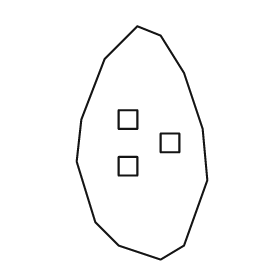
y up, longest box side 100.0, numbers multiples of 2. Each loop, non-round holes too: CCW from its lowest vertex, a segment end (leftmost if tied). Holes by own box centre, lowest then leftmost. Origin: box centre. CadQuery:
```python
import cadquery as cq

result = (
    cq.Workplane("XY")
    .moveTo(8.0, -50.0)
    .lineTo(18.0, -44.0)
    .lineTo(28.0, -16.0)
    .lineTo(26.0, 6.0)
    .lineTo(18.0, 30.0)
    .lineTo(8.0, 46.0)
    .lineTo(-2.0, 50.0)
    .lineTo(-16.0, 36.0)
    .lineTo(-26.0, 10.0)
    .lineTo(-28.0, -8.0)
    .lineTo(-20.0, -34.0)
    .lineTo(-10.0, -44.0)
    .close()
    .moveTo(-10.0, -14.0)
    .lineTo(-2.0, -14.0)
    .lineTo(-2.0, -6.0)
    .lineTo(-10.0, -6.0)
    .close()
    .moveTo(8.0, -4.0)
    .lineTo(16.0, -4.0)
    .lineTo(16.0, 4.0)
    .lineTo(8.0, 4.0)
    .close()
    .moveTo(-10.0, 6.0)
    .lineTo(-2.0, 6.0)
    .lineTo(-2.0, 14.0)
    .lineTo(-10.0, 14.0)
    .close()
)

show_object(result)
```